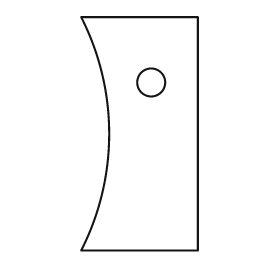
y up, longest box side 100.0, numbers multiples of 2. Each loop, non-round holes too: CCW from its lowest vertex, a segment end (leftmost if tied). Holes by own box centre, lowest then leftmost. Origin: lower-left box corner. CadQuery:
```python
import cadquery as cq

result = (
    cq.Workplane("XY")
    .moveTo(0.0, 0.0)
    .lineTo(50.0, 0.0)
    .lineTo(50.0, 100.0)
    .lineTo(0.0, 100.0)
    .threePointArc((12.0, 50.0), (0.0, 0.0))
    .close()
    .moveTo(30.0, 72.0)
    .circle(6.0)
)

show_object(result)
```